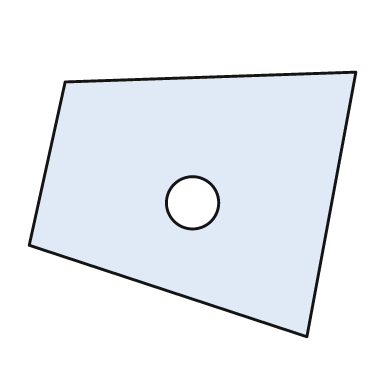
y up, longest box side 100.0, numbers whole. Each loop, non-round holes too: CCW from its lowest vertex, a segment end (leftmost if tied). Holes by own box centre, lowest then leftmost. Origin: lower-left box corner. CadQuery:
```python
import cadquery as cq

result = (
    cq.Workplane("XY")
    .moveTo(85.0, 0.0)
    .lineTo(100.0, 81.0)
    .lineTo(11.0, 78.0)
    .lineTo(0.0, 28.0)
    .close()
    .moveTo(50.0, 41.0)
    .circle(8.0)
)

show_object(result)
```